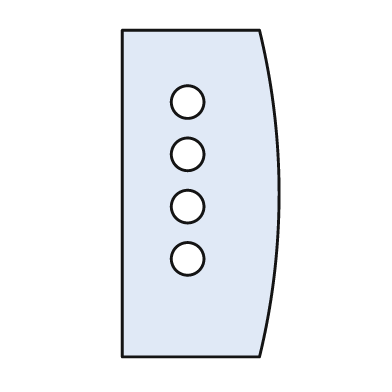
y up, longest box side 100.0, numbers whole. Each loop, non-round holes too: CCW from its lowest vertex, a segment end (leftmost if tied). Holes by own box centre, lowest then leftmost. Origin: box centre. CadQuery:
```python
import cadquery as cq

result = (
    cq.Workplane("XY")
    .moveTo(-24.0, -50.0)
    .lineTo(18.0, -50.0)
    .threePointArc((24.0, 0.0), (18.0, 50.0))
    .lineTo(-24.0, 50.0)
    .close()
    .moveTo(-4.0, -20.0)
    .circle(5.0)
    .moveTo(-4.0, -4.0)
    .circle(5.0)
    .moveTo(-4.0, 12.0)
    .circle(5.0)
    .moveTo(-4.0, 28.0)
    .circle(5.0)
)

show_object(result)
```